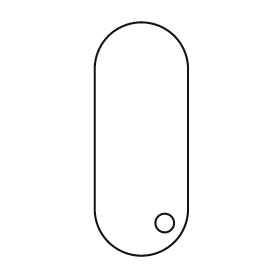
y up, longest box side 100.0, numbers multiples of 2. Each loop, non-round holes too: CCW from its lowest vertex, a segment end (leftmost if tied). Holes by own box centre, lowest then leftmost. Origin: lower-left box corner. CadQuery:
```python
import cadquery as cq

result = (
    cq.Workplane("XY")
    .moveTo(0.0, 20.0)
    .threePointArc((20.0, 0.0), (40.0, 20.0))
    .lineTo(40.0, 80.0)
    .threePointArc((20.0, 100.0), (0.0, 80.0))
    .close()
    .moveTo(30.0, 14.0)
    .circle(4.0)
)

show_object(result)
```